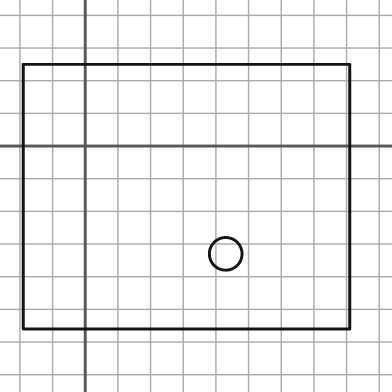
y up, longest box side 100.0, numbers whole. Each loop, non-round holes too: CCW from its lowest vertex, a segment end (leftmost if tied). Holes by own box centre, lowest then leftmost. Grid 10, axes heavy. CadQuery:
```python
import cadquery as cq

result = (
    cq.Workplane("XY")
    .moveTo(-19.0, -56.0)
    .lineTo(81.0, -56.0)
    .lineTo(81.0, 25.0)
    .lineTo(-19.0, 25.0)
    .close()
    .moveTo(43.0, -33.0)
    .circle(5.0)
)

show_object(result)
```